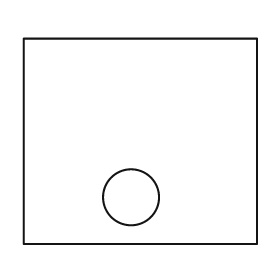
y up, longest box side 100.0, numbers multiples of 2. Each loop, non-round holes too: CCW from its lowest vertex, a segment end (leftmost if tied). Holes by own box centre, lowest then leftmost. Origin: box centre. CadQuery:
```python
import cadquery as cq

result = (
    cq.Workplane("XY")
    .moveTo(-50.0, -44.0)
    .lineTo(50.0, -44.0)
    .lineTo(50.0, 44.0)
    .lineTo(-50.0, 44.0)
    .close()
    .moveTo(-4.0, -24.0)
    .circle(12.0)
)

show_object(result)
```